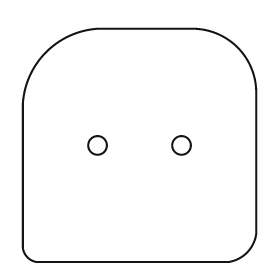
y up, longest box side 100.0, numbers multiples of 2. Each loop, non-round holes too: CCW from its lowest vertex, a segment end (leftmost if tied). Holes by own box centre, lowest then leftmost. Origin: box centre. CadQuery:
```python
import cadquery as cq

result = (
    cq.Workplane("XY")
    .moveTo(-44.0, -50.0)
    .lineTo(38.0, -50.0)
    .threePointArc((46.0, -46.0), (50.0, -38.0))
    .lineTo(50.0, 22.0)
    .threePointArc((42.0, 42.0), (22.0, 50.0))
    .lineTo(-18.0, 50.0)
    .threePointArc((-40.0, 40.0), (-50.0, 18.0))
    .lineTo(-50.0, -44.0)
    .threePointArc((-48.0, -48.0), (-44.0, -50.0))
    .close()
    .moveTo(-18.0, 0.0)
    .circle(4.0)
    .moveTo(18.0, 0.0)
    .circle(4.0)
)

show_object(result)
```